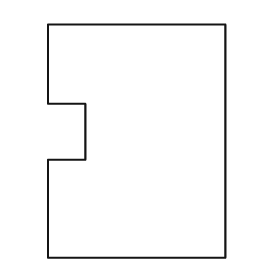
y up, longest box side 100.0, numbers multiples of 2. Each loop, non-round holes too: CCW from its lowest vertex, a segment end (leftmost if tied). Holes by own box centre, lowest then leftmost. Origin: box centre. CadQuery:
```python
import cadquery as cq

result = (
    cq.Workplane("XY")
    .moveTo(-38.0, -50.0)
    .lineTo(38.0, -50.0)
    .lineTo(38.0, 50.0)
    .lineTo(-38.0, 50.0)
    .lineTo(-38.0, 16.0)
    .lineTo(-22.0, 16.0)
    .lineTo(-22.0, -8.0)
    .lineTo(-38.0, -8.0)
    .close()
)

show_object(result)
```